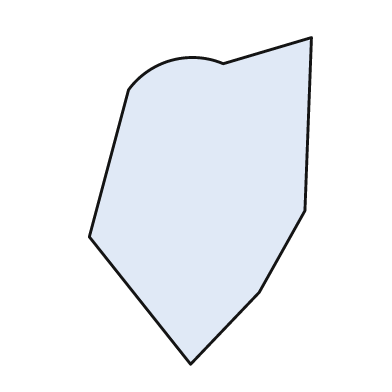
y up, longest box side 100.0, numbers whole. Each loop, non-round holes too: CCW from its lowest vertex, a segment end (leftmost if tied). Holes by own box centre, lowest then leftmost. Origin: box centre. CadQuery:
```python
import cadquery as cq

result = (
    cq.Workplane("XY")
    .moveTo(-3.0, -50.0)
    .lineTo(18.0, -28.0)
    .lineTo(32.0, -3.0)
    .lineTo(34.0, 50.0)
    .lineTo(7.0, 42.0)
    .threePointArc((-9.0, 43.0), (-22.0, 34.0))
    .lineTo(-34.0, -11.0)
    .close()
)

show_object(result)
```